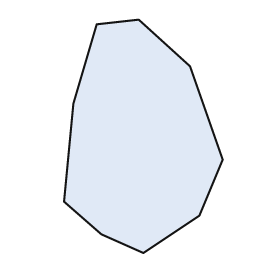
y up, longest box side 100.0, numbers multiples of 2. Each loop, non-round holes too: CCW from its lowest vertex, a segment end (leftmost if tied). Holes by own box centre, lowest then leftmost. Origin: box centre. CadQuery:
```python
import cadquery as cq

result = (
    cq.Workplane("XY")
    .moveTo(0.0, -50.0)
    .lineTo(24.0, -34.0)
    .lineTo(34.0, -10.0)
    .lineTo(20.0, 30.0)
    .lineTo(-2.0, 50.0)
    .lineTo(-20.0, 48.0)
    .lineTo(-30.0, 14.0)
    .lineTo(-34.0, -28.0)
    .lineTo(-18.0, -42.0)
    .close()
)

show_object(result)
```